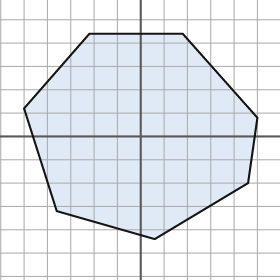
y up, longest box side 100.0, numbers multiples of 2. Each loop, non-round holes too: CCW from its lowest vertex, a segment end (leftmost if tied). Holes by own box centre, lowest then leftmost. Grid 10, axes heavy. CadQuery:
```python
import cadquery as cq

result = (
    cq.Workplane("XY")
    .moveTo(6.0, -44.0)
    .lineTo(46.0, -20.0)
    .lineTo(50.0, 8.0)
    .lineTo(18.0, 44.0)
    .lineTo(-22.0, 44.0)
    .lineTo(-50.0, 12.0)
    .lineTo(-36.0, -32.0)
    .close()
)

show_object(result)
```